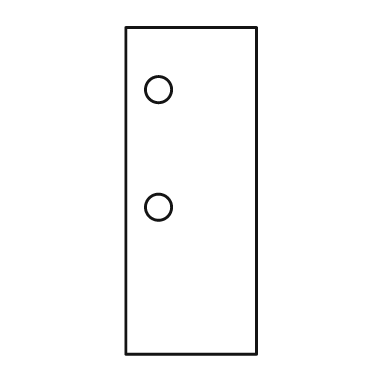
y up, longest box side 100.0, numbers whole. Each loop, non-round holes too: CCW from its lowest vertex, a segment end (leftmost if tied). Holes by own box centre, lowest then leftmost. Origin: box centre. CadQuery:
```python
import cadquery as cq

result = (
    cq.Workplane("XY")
    .moveTo(-20.0, -50.0)
    .lineTo(20.0, -50.0)
    .lineTo(20.0, 50.0)
    .lineTo(-20.0, 50.0)
    .close()
    .moveTo(-10.0, -5.0)
    .circle(4.0)
    .moveTo(-10.0, 31.0)
    .circle(4.0)
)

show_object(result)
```